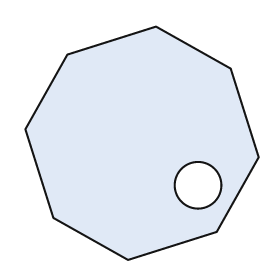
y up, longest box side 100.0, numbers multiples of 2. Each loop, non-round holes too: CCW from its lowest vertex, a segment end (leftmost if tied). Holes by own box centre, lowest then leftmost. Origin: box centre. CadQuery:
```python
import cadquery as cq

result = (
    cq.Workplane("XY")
    .moveTo(-6.0, -50.0)
    .lineTo(32.0, -38.0)
    .lineTo(50.0, -6.0)
    .lineTo(38.0, 32.0)
    .lineTo(6.0, 50.0)
    .lineTo(-32.0, 38.0)
    .lineTo(-50.0, 6.0)
    .lineTo(-38.0, -32.0)
    .close()
    .moveTo(24.0, -18.0)
    .circle(10.0)
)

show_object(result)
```